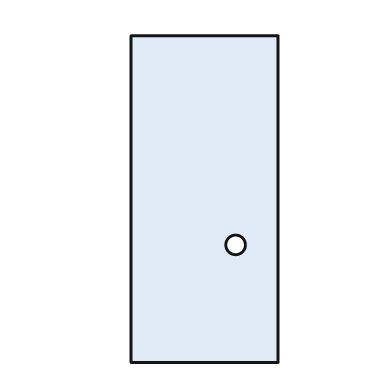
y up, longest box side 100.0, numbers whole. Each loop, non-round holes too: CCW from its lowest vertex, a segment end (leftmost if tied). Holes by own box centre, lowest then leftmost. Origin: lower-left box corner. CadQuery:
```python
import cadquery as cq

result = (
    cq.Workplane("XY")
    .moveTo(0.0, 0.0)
    .lineTo(45.0, 0.0)
    .lineTo(45.0, 100.0)
    .lineTo(0.0, 100.0)
    .close()
    .moveTo(32.0, 36.0)
    .circle(3.0)
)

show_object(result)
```